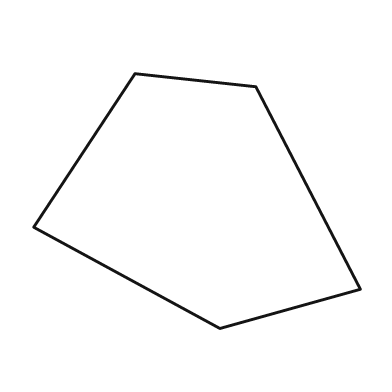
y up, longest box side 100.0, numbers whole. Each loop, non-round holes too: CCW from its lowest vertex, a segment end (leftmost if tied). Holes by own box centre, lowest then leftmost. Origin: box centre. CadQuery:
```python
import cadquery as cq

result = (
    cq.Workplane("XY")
    .moveTo(7.0, -39.0)
    .lineTo(50.0, -27.0)
    .lineTo(18.0, 35.0)
    .lineTo(-19.0, 39.0)
    .lineTo(-50.0, -8.0)
    .close()
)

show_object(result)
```